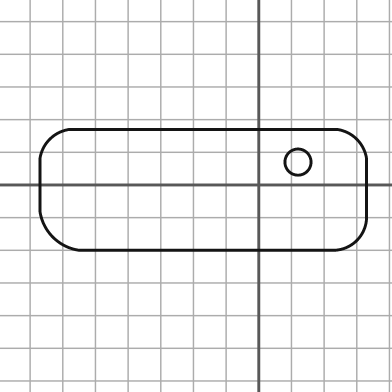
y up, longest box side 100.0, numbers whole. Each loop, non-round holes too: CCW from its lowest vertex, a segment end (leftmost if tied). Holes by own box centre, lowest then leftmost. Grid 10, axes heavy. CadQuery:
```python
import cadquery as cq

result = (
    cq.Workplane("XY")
    .moveTo(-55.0, -20.0)
    .lineTo(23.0, -20.0)
    .threePointArc((30.0, -17.0), (33.0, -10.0))
    .lineTo(33.0, 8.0)
    .threePointArc((30.0, 14.0), (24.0, 17.0))
    .lineTo(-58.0, 17.0)
    .threePointArc((-64.0, 14.0), (-67.0, 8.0))
    .lineTo(-67.0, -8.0)
    .threePointArc((-63.0, -16.0), (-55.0, -20.0))
    .close()
    .moveTo(12.0, 7.0)
    .circle(4.0)
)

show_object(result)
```